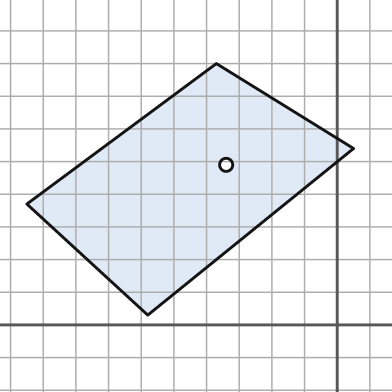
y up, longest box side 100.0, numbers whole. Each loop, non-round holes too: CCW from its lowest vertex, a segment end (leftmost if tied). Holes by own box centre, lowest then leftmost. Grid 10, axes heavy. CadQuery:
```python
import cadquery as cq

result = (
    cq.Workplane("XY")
    .moveTo(-58.0, 3.0)
    .lineTo(5.0, 54.0)
    .lineTo(-37.0, 80.0)
    .lineTo(-95.0, 37.0)
    .close()
    .moveTo(-34.0, 49.0)
    .circle(2.0)
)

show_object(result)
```